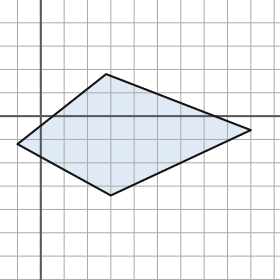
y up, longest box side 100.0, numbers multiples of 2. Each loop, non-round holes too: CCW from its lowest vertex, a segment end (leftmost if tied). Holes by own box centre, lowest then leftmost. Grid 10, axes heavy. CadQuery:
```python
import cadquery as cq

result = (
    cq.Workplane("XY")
    .moveTo(30.0, -34.0)
    .lineTo(90.0, -6.0)
    .lineTo(28.0, 18.0)
    .lineTo(-10.0, -12.0)
    .close()
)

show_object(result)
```